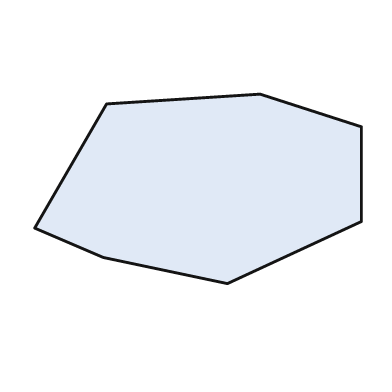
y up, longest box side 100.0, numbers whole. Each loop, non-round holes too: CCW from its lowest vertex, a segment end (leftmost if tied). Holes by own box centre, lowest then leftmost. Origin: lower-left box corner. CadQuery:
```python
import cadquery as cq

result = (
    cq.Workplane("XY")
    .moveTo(59.0, 0.0)
    .lineTo(100.0, 19.0)
    .lineTo(100.0, 48.0)
    .lineTo(69.0, 58.0)
    .lineTo(22.0, 55.0)
    .lineTo(0.0, 17.0)
    .lineTo(21.0, 8.0)
    .close()
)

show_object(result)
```